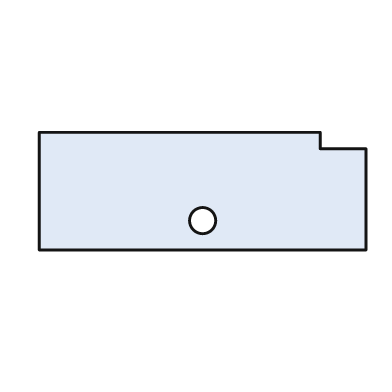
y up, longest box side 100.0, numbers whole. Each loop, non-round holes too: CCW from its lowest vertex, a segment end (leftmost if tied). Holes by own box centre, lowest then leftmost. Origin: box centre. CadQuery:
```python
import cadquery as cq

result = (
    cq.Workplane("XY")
    .moveTo(-50.0, -18.0)
    .lineTo(50.0, -18.0)
    .lineTo(50.0, 13.0)
    .lineTo(36.0, 13.0)
    .lineTo(36.0, 18.0)
    .lineTo(-50.0, 18.0)
    .close()
    .moveTo(0.0, -9.0)
    .circle(4.0)
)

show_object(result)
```